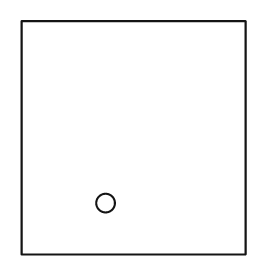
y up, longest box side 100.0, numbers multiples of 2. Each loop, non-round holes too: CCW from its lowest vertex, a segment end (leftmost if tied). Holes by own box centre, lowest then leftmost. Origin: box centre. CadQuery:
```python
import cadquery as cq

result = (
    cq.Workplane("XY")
    .moveTo(-48.0, -50.0)
    .lineTo(48.0, -50.0)
    .lineTo(48.0, 50.0)
    .lineTo(-48.0, 50.0)
    .close()
    .moveTo(-12.0, -28.0)
    .circle(4.0)
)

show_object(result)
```